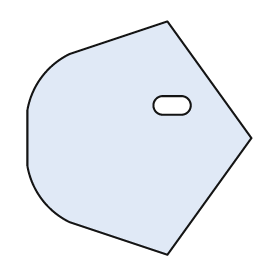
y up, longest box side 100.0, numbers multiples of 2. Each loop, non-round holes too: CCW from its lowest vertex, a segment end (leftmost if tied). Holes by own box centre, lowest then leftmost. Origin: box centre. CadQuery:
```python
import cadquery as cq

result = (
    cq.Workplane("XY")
    .moveTo(12.0, -50.0)
    .lineTo(48.0, 0.0)
    .lineTo(12.0, 50.0)
    .lineTo(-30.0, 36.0)
    .threePointArc((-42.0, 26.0), (-48.0, 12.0))
    .lineTo(-48.0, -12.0)
    .threePointArc((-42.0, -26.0), (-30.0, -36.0))
    .close()
    .moveTo(10.0, 10.0)
    .lineTo(18.0, 10.0)
    .threePointArc((22.0, 14.0), (18.0, 18.0))
    .lineTo(10.0, 18.0)
    .threePointArc((6.0, 14.0), (10.0, 10.0))
    .close()
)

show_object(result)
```